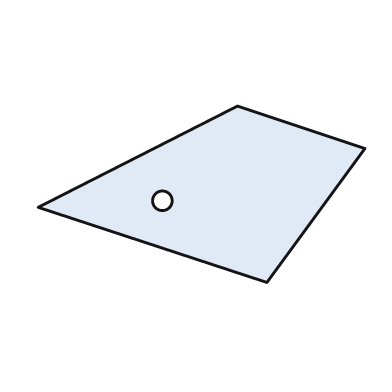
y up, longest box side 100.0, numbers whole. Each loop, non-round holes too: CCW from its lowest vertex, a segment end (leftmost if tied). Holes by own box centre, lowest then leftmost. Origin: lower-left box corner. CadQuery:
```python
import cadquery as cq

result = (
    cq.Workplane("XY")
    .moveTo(70.0, 0.0)
    .lineTo(100.0, 41.0)
    .lineTo(61.0, 54.0)
    .lineTo(0.0, 23.0)
    .close()
    .moveTo(38.0, 25.0)
    .circle(3.0)
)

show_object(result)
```